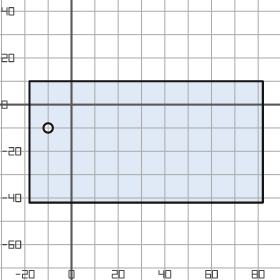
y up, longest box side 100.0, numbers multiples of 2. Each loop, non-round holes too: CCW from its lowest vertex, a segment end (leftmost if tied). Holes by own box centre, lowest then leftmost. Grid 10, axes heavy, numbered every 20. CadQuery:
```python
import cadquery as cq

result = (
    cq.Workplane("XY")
    .moveTo(-18.0, -42.0)
    .lineTo(82.0, -42.0)
    .lineTo(82.0, 10.0)
    .lineTo(-18.0, 10.0)
    .close()
    .moveTo(-10.0, -10.0)
    .circle(2.0)
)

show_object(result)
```